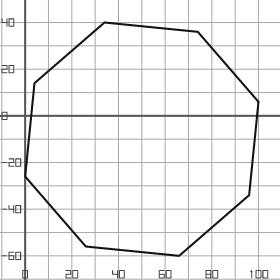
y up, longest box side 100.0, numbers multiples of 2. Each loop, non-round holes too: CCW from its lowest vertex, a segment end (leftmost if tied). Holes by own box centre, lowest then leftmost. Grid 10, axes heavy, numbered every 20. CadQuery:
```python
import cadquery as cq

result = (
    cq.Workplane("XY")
    .moveTo(66.0, -60.0)
    .lineTo(96.0, -34.0)
    .lineTo(100.0, 6.0)
    .lineTo(74.0, 36.0)
    .lineTo(34.0, 40.0)
    .lineTo(4.0, 14.0)
    .lineTo(0.0, -26.0)
    .lineTo(26.0, -56.0)
    .close()
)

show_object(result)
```